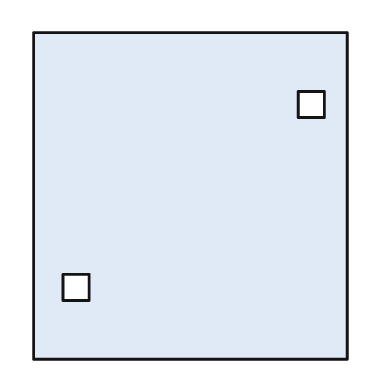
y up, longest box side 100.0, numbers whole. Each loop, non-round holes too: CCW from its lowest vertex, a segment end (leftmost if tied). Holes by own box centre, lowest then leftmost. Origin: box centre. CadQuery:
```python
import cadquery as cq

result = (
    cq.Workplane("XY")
    .moveTo(-48.0, -50.0)
    .lineTo(48.0, -50.0)
    .lineTo(48.0, 50.0)
    .lineTo(-48.0, 50.0)
    .close()
    .moveTo(-39.0, -32.0)
    .lineTo(-31.0, -32.0)
    .lineTo(-31.0, -24.0)
    .lineTo(-39.0, -24.0)
    .close()
    .moveTo(33.0, 24.0)
    .lineTo(41.0, 24.0)
    .lineTo(41.0, 32.0)
    .lineTo(33.0, 32.0)
    .close()
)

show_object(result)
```